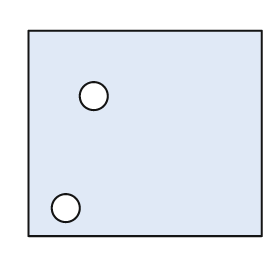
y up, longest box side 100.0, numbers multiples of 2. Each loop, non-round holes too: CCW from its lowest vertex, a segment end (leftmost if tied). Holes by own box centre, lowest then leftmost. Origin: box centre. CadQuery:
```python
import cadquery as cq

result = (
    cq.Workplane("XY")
    .moveTo(-50.0, -44.0)
    .lineTo(50.0, -44.0)
    .lineTo(50.0, 44.0)
    .lineTo(-50.0, 44.0)
    .close()
    .moveTo(-34.0, -32.0)
    .circle(6.0)
    .moveTo(-22.0, 16.0)
    .circle(6.0)
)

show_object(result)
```